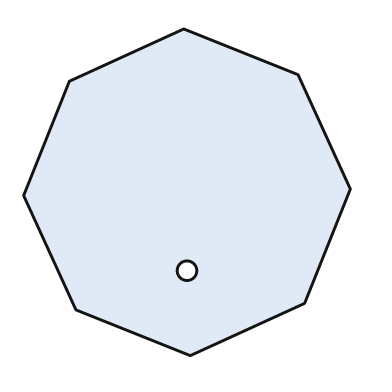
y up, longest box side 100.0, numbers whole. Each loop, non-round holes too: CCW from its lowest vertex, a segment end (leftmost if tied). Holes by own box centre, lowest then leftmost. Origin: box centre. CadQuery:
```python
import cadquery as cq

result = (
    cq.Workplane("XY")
    .moveTo(1.0, -50.0)
    .lineTo(36.0, -34.0)
    .lineTo(50.0, 1.0)
    .lineTo(34.0, 36.0)
    .lineTo(-1.0, 50.0)
    .lineTo(-36.0, 34.0)
    .lineTo(-50.0, -1.0)
    .lineTo(-34.0, -36.0)
    .close()
    .moveTo(0.0, -24.0)
    .circle(3.0)
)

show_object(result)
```